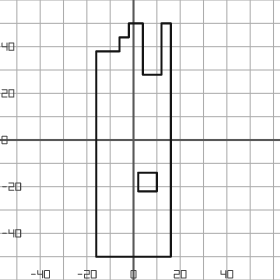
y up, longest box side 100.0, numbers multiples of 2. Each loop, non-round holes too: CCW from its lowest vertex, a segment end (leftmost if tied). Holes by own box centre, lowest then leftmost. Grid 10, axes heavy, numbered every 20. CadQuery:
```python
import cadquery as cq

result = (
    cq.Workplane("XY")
    .moveTo(-16.0, -50.0)
    .lineTo(16.0, -50.0)
    .lineTo(16.0, 50.0)
    .lineTo(12.0, 50.0)
    .lineTo(12.0, 28.0)
    .lineTo(4.0, 28.0)
    .lineTo(4.0, 50.0)
    .lineTo(-2.0, 50.0)
    .lineTo(-2.0, 44.0)
    .lineTo(-6.0, 44.0)
    .lineTo(-6.0, 38.0)
    .lineTo(-16.0, 38.0)
    .close()
    .moveTo(2.0, -22.0)
    .lineTo(10.0, -22.0)
    .lineTo(10.0, -14.0)
    .lineTo(2.0, -14.0)
    .close()
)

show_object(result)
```